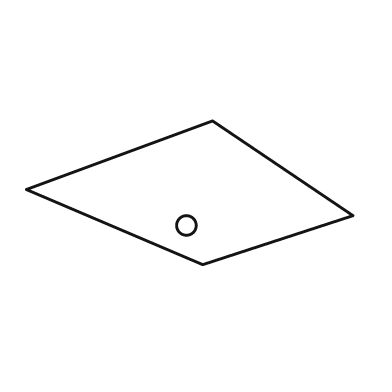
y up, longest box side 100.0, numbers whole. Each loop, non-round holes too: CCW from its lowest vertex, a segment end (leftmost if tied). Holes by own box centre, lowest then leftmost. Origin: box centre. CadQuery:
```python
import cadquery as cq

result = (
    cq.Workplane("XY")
    .moveTo(4.0, -22.0)
    .lineTo(50.0, -7.0)
    .lineTo(7.0, 22.0)
    .lineTo(-50.0, 1.0)
    .close()
    .moveTo(-1.0, -10.0)
    .circle(3.0)
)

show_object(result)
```